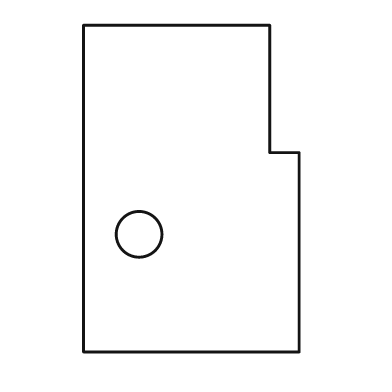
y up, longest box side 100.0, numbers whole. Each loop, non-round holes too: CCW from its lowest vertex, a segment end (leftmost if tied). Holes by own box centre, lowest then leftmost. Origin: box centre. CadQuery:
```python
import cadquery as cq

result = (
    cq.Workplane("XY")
    .moveTo(-33.0, -50.0)
    .lineTo(33.0, -50.0)
    .lineTo(33.0, 11.0)
    .lineTo(24.0, 11.0)
    .lineTo(24.0, 50.0)
    .lineTo(-33.0, 50.0)
    .close()
    .moveTo(-16.0, -14.0)
    .circle(7.0)
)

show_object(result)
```